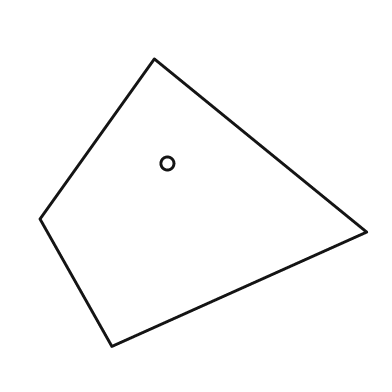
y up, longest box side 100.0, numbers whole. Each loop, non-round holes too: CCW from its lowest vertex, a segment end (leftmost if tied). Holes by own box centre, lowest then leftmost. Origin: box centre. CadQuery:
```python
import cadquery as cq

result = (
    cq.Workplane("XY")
    .moveTo(-28.0, -44.0)
    .lineTo(50.0, -9.0)
    .lineTo(-15.0, 44.0)
    .lineTo(-50.0, -5.0)
    .close()
    .moveTo(-11.0, 12.0)
    .circle(2.0)
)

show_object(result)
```